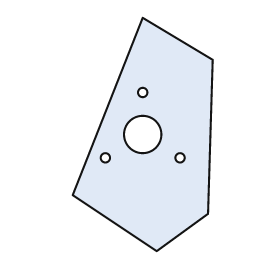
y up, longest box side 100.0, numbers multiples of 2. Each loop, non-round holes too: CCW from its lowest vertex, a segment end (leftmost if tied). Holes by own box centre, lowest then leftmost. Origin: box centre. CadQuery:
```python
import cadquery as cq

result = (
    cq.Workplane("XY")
    .moveTo(6.0, -50.0)
    .lineTo(28.0, -34.0)
    .lineTo(30.0, 32.0)
    .lineTo(0.0, 50.0)
    .lineTo(-30.0, -26.0)
    .close()
    .moveTo(-16.0, -10.0)
    .circle(2.0)
    .moveTo(16.0, -10.0)
    .circle(2.0)
    .moveTo(0.0, 0.0)
    .circle(8.0)
    .moveTo(0.0, 18.0)
    .circle(2.0)
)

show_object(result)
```